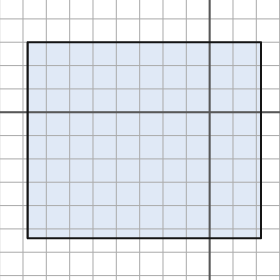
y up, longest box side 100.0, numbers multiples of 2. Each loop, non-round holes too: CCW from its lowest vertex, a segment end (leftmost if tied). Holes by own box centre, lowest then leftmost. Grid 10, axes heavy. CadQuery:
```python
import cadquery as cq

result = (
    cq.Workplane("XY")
    .moveTo(-78.0, -54.0)
    .lineTo(22.0, -54.0)
    .lineTo(22.0, 30.0)
    .lineTo(-78.0, 30.0)
    .close()
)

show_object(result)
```